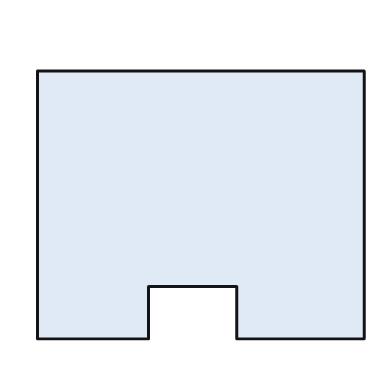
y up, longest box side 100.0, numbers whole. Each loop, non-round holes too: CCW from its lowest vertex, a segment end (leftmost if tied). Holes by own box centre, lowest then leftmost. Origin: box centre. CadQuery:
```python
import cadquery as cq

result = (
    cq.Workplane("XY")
    .moveTo(-50.0, -41.0)
    .lineTo(-16.0, -41.0)
    .lineTo(-16.0, -25.0)
    .lineTo(11.0, -25.0)
    .lineTo(11.0, -41.0)
    .lineTo(50.0, -41.0)
    .lineTo(50.0, 41.0)
    .lineTo(-50.0, 41.0)
    .close()
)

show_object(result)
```